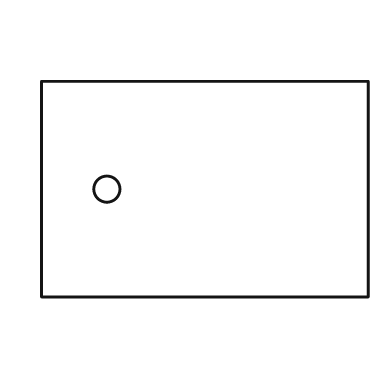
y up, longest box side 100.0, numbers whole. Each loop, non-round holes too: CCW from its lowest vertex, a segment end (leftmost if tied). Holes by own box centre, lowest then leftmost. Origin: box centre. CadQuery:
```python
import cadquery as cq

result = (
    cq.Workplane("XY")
    .moveTo(-50.0, -33.0)
    .lineTo(50.0, -33.0)
    .lineTo(50.0, 33.0)
    .lineTo(-50.0, 33.0)
    .close()
    .moveTo(-30.0, 0.0)
    .circle(4.0)
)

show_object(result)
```